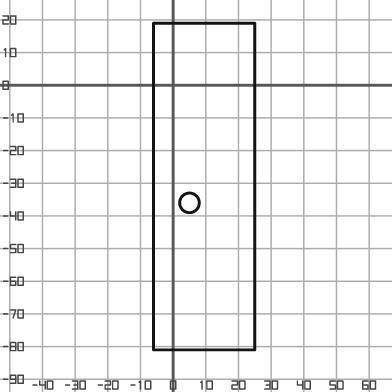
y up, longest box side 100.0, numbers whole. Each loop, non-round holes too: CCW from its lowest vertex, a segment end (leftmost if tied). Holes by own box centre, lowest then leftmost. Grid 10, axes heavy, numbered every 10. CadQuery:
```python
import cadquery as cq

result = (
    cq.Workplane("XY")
    .moveTo(-6.0, -81.0)
    .lineTo(25.0, -81.0)
    .lineTo(25.0, 19.0)
    .lineTo(-6.0, 19.0)
    .close()
    .moveTo(5.0, -36.0)
    .circle(3.0)
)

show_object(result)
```